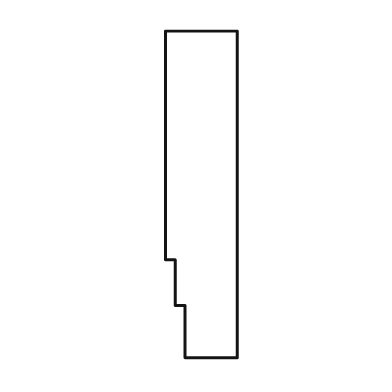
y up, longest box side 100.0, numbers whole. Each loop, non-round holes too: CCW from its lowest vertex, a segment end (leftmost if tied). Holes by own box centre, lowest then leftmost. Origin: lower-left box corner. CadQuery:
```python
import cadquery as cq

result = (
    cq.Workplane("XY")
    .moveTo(6.0, 0.0)
    .lineTo(22.0, 0.0)
    .lineTo(22.0, 100.0)
    .lineTo(0.0, 100.0)
    .lineTo(0.0, 30.0)
    .lineTo(3.0, 30.0)
    .lineTo(3.0, 16.0)
    .lineTo(6.0, 16.0)
    .close()
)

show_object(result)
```